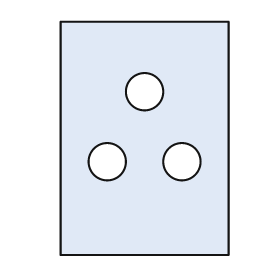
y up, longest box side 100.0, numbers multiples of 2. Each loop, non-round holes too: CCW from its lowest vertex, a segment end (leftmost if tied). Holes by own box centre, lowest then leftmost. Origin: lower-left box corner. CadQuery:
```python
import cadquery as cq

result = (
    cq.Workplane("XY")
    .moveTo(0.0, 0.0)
    .lineTo(72.0, 0.0)
    .lineTo(72.0, 100.0)
    .lineTo(0.0, 100.0)
    .close()
    .moveTo(20.0, 40.0)
    .circle(8.0)
    .moveTo(52.0, 40.0)
    .circle(8.0)
    .moveTo(36.0, 70.0)
    .circle(8.0)
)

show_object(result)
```